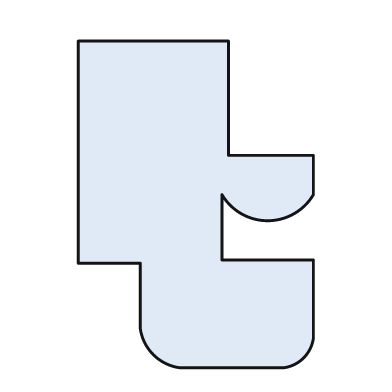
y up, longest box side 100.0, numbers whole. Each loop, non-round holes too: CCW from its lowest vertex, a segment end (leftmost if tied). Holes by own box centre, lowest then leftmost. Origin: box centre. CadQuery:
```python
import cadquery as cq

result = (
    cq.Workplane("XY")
    .moveTo(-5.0, -50.0)
    .lineTo(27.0, -50.0)
    .threePointArc((33.0, -47.0), (36.0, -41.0))
    .lineTo(36.0, -17.0)
    .lineTo(8.0, -17.0)
    .lineTo(8.0, 3.0)
    .threePointArc((22.0, -5.0), (36.0, 3.0))
    .lineTo(36.0, 15.0)
    .lineTo(10.0, 15.0)
    .lineTo(10.0, 50.0)
    .lineTo(-36.0, 50.0)
    .lineTo(-36.0, -18.0)
    .lineTo(-17.0, -18.0)
    .lineTo(-17.0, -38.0)
    .threePointArc((-13.0, -46.0), (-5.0, -50.0))
    .close()
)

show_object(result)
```